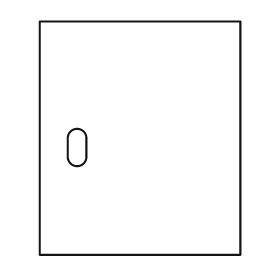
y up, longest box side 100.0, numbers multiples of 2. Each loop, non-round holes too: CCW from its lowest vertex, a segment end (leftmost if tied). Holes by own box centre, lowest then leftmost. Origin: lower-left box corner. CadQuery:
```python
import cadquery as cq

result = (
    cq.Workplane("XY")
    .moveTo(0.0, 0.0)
    .lineTo(86.0, 0.0)
    .lineTo(86.0, 100.0)
    .lineTo(0.0, 100.0)
    .close()
    .moveTo(12.0, 42.0)
    .threePointArc((16.0, 38.0), (20.0, 42.0))
    .lineTo(20.0, 50.0)
    .threePointArc((16.0, 54.0), (12.0, 50.0))
    .close()
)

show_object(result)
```